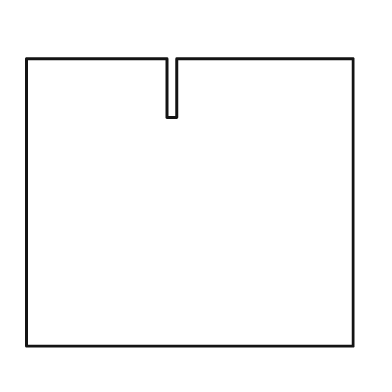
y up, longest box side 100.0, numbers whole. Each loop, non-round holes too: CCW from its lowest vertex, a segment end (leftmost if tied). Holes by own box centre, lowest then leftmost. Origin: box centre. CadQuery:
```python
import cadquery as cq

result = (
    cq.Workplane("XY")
    .moveTo(-50.0, -44.0)
    .lineTo(50.0, -44.0)
    .lineTo(50.0, 44.0)
    .lineTo(-4.0, 44.0)
    .lineTo(-4.0, 26.0)
    .lineTo(-7.0, 26.0)
    .lineTo(-7.0, 44.0)
    .lineTo(-50.0, 44.0)
    .close()
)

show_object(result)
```